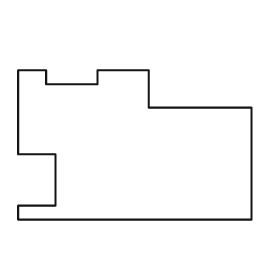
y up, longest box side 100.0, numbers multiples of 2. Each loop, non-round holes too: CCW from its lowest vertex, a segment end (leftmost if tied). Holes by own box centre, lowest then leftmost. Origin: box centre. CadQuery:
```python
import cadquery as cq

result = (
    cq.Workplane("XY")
    .moveTo(-50.0, -32.0)
    .lineTo(50.0, -32.0)
    .lineTo(50.0, 16.0)
    .lineTo(6.0, 16.0)
    .lineTo(6.0, 32.0)
    .lineTo(-16.0, 32.0)
    .lineTo(-16.0, 26.0)
    .lineTo(-38.0, 26.0)
    .lineTo(-38.0, 32.0)
    .lineTo(-50.0, 32.0)
    .lineTo(-50.0, -4.0)
    .lineTo(-34.0, -4.0)
    .lineTo(-34.0, -26.0)
    .lineTo(-50.0, -26.0)
    .close()
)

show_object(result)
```